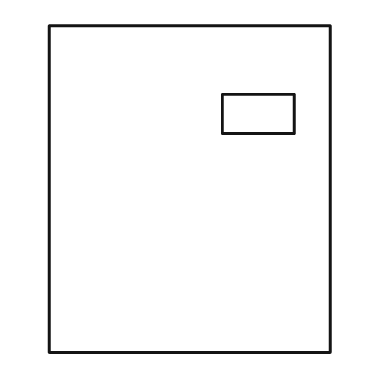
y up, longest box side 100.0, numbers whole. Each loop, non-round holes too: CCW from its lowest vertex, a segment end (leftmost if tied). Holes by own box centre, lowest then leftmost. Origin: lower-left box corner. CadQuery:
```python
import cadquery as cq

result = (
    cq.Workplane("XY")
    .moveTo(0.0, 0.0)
    .lineTo(86.0, 0.0)
    .lineTo(86.0, 100.0)
    .lineTo(0.0, 100.0)
    .close()
    .moveTo(53.0, 67.0)
    .lineTo(75.0, 67.0)
    .lineTo(75.0, 79.0)
    .lineTo(53.0, 79.0)
    .close()
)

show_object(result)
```